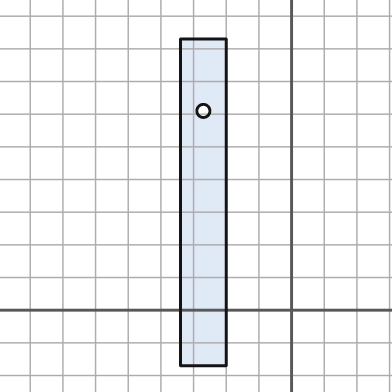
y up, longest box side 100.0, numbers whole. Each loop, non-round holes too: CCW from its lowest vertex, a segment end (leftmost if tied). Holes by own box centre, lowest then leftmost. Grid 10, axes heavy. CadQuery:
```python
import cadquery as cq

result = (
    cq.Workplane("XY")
    .moveTo(-34.0, -17.0)
    .lineTo(-20.0, -17.0)
    .lineTo(-20.0, 83.0)
    .lineTo(-34.0, 83.0)
    .close()
    .moveTo(-27.0, 61.0)
    .circle(2.0)
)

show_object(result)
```